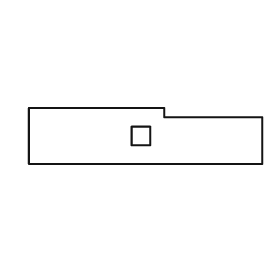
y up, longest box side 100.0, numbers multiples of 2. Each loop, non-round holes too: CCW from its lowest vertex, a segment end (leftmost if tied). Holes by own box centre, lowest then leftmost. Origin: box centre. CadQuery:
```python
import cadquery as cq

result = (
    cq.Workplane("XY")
    .moveTo(-50.0, -12.0)
    .lineTo(50.0, -12.0)
    .lineTo(50.0, 8.0)
    .lineTo(8.0, 8.0)
    .lineTo(8.0, 12.0)
    .lineTo(-50.0, 12.0)
    .close()
    .moveTo(-6.0, -4.0)
    .lineTo(2.0, -4.0)
    .lineTo(2.0, 4.0)
    .lineTo(-6.0, 4.0)
    .close()
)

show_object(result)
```